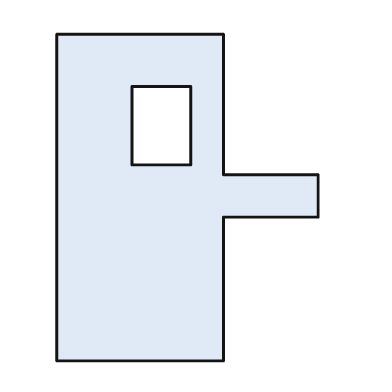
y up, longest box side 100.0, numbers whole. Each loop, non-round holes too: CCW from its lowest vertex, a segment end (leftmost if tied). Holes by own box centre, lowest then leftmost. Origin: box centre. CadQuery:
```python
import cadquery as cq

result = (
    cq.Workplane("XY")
    .moveTo(-40.0, -50.0)
    .lineTo(11.0, -50.0)
    .lineTo(11.0, -6.0)
    .lineTo(40.0, -6.0)
    .lineTo(40.0, 7.0)
    .lineTo(11.0, 7.0)
    .lineTo(11.0, 50.0)
    .lineTo(-40.0, 50.0)
    .close()
    .moveTo(-17.0, 10.0)
    .lineTo(1.0, 10.0)
    .lineTo(1.0, 34.0)
    .lineTo(-17.0, 34.0)
    .close()
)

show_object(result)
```